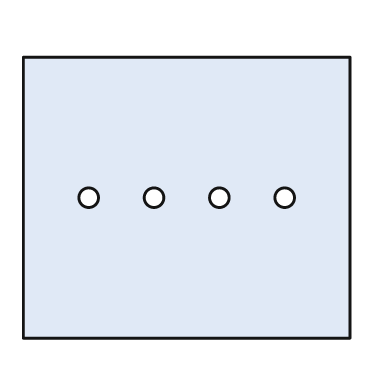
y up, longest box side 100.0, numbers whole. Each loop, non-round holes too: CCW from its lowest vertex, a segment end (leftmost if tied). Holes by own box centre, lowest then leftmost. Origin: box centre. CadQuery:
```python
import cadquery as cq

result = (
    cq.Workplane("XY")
    .moveTo(-50.0, -43.0)
    .lineTo(50.0, -43.0)
    .lineTo(50.0, 43.0)
    .lineTo(-50.0, 43.0)
    .close()
    .moveTo(-30.0, 0.0)
    .circle(3.0)
    .moveTo(-10.0, 0.0)
    .circle(3.0)
    .moveTo(10.0, 0.0)
    .circle(3.0)
    .moveTo(30.0, 0.0)
    .circle(3.0)
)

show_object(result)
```